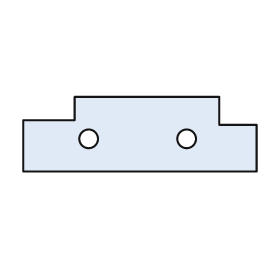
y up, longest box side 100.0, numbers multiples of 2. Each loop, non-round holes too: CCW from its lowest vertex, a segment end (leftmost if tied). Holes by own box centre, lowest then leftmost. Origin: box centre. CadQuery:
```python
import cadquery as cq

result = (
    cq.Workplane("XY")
    .moveTo(-50.0, -16.0)
    .lineTo(50.0, -16.0)
    .lineTo(50.0, 4.0)
    .lineTo(34.0, 4.0)
    .lineTo(34.0, 16.0)
    .lineTo(-28.0, 16.0)
    .lineTo(-28.0, 6.0)
    .lineTo(-50.0, 6.0)
    .close()
    .moveTo(-22.0, -2.0)
    .circle(4.0)
    .moveTo(20.0, -2.0)
    .circle(4.0)
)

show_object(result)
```